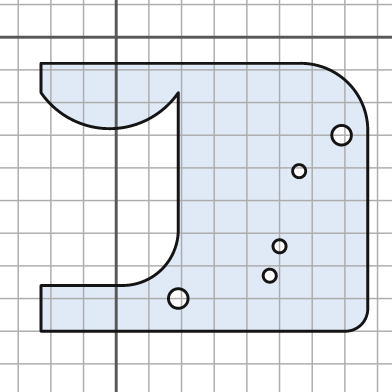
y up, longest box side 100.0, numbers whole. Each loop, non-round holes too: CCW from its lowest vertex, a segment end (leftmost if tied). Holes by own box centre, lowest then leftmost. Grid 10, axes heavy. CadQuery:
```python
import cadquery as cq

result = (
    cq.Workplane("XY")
    .moveTo(-23.0, -90.0)
    .lineTo(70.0, -90.0)
    .threePointArc((75.0, -88.0), (77.0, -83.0))
    .lineTo(77.0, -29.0)
    .threePointArc((71.0, -14.0), (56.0, -8.0))
    .lineTo(-23.0, -8.0)
    .lineTo(-23.0, -17.0)
    .threePointArc((-2.0, -28.0), (19.0, -17.0))
    .lineTo(19.0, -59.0)
    .threePointArc((14.0, -71.0), (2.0, -76.0))
    .lineTo(-23.0, -76.0)
    .close()
    .moveTo(19.0, -80.0)
    .circle(3.0)
    .moveTo(47.0, -73.0)
    .circle(2.0)
    .moveTo(50.0, -64.0)
    .circle(2.0)
    .moveTo(56.0, -41.0)
    .circle(2.0)
    .moveTo(69.0, -30.0)
    .circle(3.0)
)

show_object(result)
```